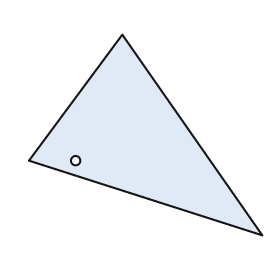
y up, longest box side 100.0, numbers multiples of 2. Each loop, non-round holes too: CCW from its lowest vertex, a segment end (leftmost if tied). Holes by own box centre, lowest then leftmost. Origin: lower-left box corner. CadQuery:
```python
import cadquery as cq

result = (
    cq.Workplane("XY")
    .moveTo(100.0, 0.0)
    .lineTo(40.0, 86.0)
    .lineTo(0.0, 32.0)
    .close()
    .moveTo(20.0, 32.0)
    .circle(2.0)
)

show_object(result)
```